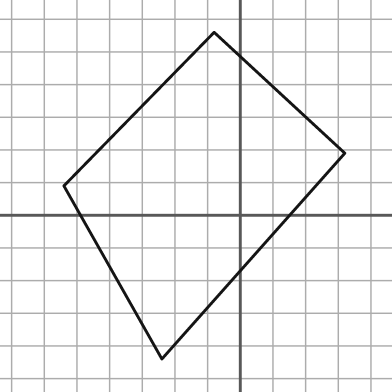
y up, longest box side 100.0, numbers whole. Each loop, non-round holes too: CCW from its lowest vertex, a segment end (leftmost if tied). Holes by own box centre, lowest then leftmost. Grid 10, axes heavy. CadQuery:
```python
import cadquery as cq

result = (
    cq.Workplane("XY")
    .moveTo(-24.0, -44.0)
    .lineTo(32.0, 19.0)
    .lineTo(-8.0, 56.0)
    .lineTo(-54.0, 9.0)
    .close()
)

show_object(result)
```